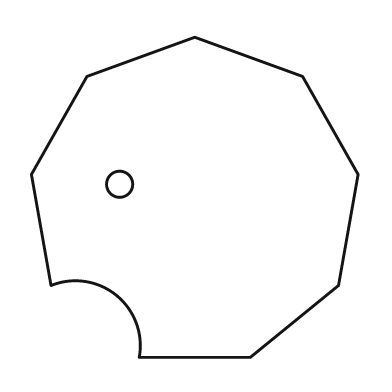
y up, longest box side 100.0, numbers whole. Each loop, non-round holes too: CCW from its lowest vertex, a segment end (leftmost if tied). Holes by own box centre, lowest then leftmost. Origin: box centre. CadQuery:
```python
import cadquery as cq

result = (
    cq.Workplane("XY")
    .moveTo(-17.0, -49.0)
    .lineTo(17.0, -49.0)
    .lineTo(44.0, -27.0)
    .lineTo(50.0, 7.0)
    .lineTo(33.0, 37.0)
    .lineTo(0.0, 49.0)
    .lineTo(-33.0, 37.0)
    .lineTo(-50.0, 7.0)
    .lineTo(-44.0, -27.0)
    .threePointArc((-24.0, -30.0), (-17.0, -49.0))
    .close()
    .moveTo(-23.0, 4.0)
    .circle(4.0)
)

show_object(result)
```